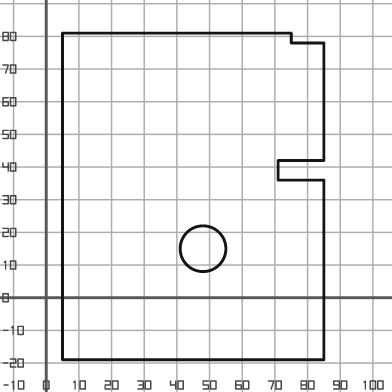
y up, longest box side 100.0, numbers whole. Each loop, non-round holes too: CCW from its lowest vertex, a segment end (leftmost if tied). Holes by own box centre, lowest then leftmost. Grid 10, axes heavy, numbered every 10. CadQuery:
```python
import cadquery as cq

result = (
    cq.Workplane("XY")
    .moveTo(5.0, -19.0)
    .lineTo(85.0, -19.0)
    .lineTo(85.0, 36.0)
    .lineTo(71.0, 36.0)
    .lineTo(71.0, 42.0)
    .lineTo(85.0, 42.0)
    .lineTo(85.0, 78.0)
    .lineTo(75.0, 78.0)
    .lineTo(75.0, 81.0)
    .lineTo(5.0, 81.0)
    .close()
    .moveTo(48.0, 15.0)
    .circle(7.0)
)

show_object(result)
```